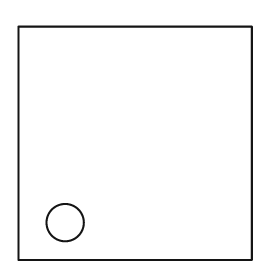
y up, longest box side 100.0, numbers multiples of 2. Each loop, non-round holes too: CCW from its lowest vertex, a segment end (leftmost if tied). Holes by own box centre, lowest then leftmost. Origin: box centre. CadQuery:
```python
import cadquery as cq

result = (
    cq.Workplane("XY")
    .moveTo(-50.0, -50.0)
    .lineTo(50.0, -50.0)
    .lineTo(50.0, 50.0)
    .lineTo(-50.0, 50.0)
    .close()
    .moveTo(-30.0, -34.0)
    .circle(8.0)
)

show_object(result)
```